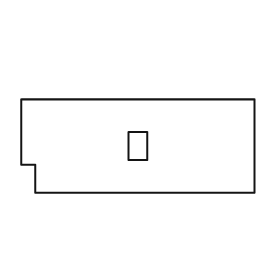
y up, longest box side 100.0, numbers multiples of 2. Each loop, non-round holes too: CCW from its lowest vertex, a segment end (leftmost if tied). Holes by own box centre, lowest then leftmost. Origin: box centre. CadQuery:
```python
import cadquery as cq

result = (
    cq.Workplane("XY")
    .moveTo(-44.0, -20.0)
    .lineTo(50.0, -20.0)
    .lineTo(50.0, 20.0)
    .lineTo(-50.0, 20.0)
    .lineTo(-50.0, -8.0)
    .lineTo(-44.0, -8.0)
    .close()
    .moveTo(-4.0, -6.0)
    .lineTo(4.0, -6.0)
    .lineTo(4.0, 6.0)
    .lineTo(-4.0, 6.0)
    .close()
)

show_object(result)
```